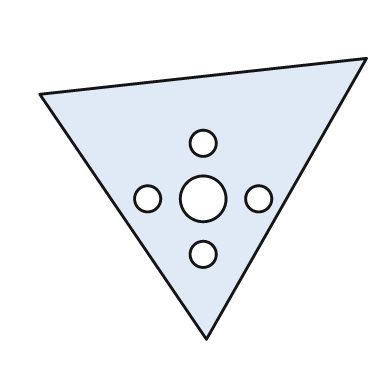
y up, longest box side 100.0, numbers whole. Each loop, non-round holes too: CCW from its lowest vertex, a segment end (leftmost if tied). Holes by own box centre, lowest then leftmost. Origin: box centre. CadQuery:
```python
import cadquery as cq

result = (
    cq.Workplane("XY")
    .moveTo(1.0, -43.0)
    .lineTo(50.0, 43.0)
    .lineTo(-50.0, 32.0)
    .close()
    .moveTo(0.0, -17.0)
    .circle(4.0)
    .moveTo(-17.0, 0.0)
    .circle(4.0)
    .moveTo(0.0, 0.0)
    .circle(7.0)
    .moveTo(17.0, 0.0)
    .circle(4.0)
    .moveTo(0.0, 17.0)
    .circle(4.0)
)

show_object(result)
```